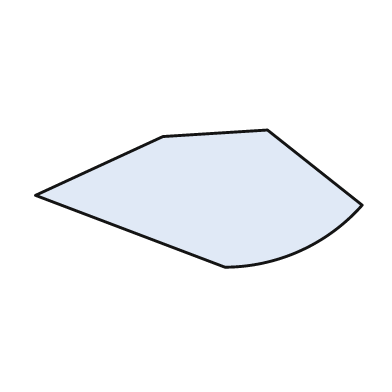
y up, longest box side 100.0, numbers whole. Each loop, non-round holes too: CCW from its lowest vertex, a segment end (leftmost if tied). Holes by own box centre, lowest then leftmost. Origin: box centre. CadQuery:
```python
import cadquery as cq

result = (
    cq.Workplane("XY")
    .moveTo(8.0, -21.0)
    .threePointArc((31.0, -16.0), (50.0, -2.0))
    .lineTo(21.0, 21.0)
    .lineTo(-11.0, 19.0)
    .lineTo(-50.0, 1.0)
    .close()
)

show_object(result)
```